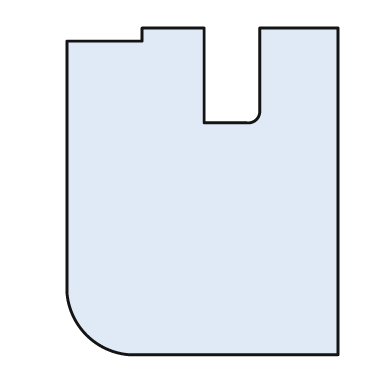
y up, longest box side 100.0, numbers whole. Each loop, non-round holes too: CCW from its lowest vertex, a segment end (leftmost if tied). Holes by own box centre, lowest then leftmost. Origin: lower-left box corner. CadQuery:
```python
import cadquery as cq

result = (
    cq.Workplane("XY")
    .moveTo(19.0, 0.0)
    .lineTo(83.0, 0.0)
    .lineTo(83.0, 100.0)
    .lineTo(59.0, 100.0)
    .lineTo(59.0, 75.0)
    .threePointArc((58.0, 72.0), (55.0, 71.0))
    .lineTo(42.0, 71.0)
    .lineTo(42.0, 100.0)
    .lineTo(23.0, 100.0)
    .lineTo(23.0, 96.0)
    .lineTo(0.0, 96.0)
    .lineTo(0.0, 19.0)
    .threePointArc((6.0, 6.0), (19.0, 0.0))
    .close()
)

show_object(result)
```